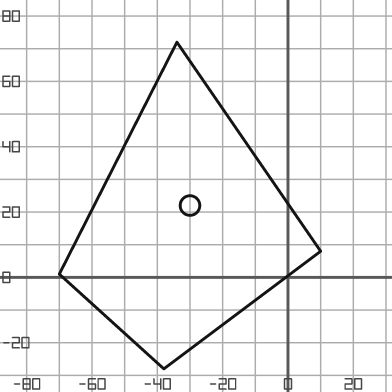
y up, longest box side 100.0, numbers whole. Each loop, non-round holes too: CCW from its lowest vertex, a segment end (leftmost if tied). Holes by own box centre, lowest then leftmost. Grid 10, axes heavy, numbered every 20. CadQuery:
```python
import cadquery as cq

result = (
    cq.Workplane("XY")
    .moveTo(-38.0, -28.0)
    .lineTo(10.0, 8.0)
    .lineTo(-34.0, 72.0)
    .lineTo(-70.0, 1.0)
    .close()
    .moveTo(-30.0, 22.0)
    .circle(3.0)
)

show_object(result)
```